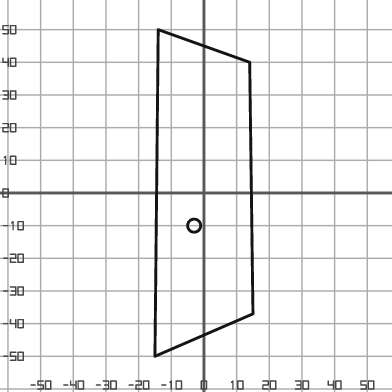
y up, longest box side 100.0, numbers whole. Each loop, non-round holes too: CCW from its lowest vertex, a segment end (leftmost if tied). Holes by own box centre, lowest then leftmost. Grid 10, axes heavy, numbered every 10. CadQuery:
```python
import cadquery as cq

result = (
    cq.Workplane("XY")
    .moveTo(-15.0, -50.0)
    .lineTo(15.0, -37.0)
    .lineTo(14.0, 40.0)
    .lineTo(-14.0, 50.0)
    .close()
    .moveTo(-3.0, -10.0)
    .circle(2.0)
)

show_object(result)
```